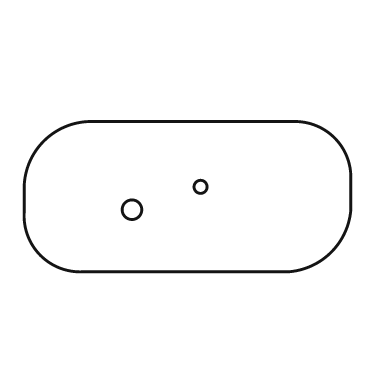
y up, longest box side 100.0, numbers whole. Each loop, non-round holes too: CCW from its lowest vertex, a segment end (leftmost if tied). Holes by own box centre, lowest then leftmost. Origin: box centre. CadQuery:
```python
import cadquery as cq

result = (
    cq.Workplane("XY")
    .moveTo(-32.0, -23.0)
    .lineTo(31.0, -23.0)
    .threePointArc((44.0, -17.0), (50.0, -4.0))
    .lineTo(50.0, 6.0)
    .threePointArc((45.0, 18.0), (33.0, 23.0))
    .lineTo(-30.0, 23.0)
    .threePointArc((-44.0, 17.0), (-50.0, 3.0))
    .lineTo(-50.0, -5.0)
    .threePointArc((-45.0, -18.0), (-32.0, -23.0))
    .close()
    .moveTo(-17.0, -4.0)
    .circle(3.0)
    .moveTo(4.0, 3.0)
    .circle(2.0)
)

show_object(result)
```